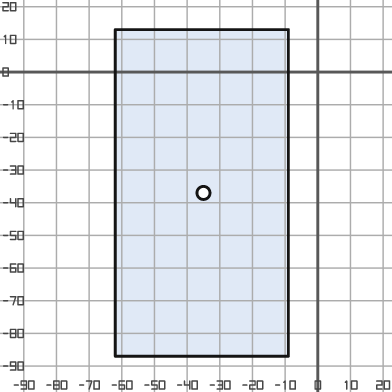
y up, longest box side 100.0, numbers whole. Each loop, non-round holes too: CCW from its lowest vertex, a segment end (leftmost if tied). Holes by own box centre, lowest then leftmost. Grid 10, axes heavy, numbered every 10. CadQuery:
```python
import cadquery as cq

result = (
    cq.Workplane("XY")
    .moveTo(-62.0, -87.0)
    .lineTo(-9.0, -87.0)
    .lineTo(-9.0, 13.0)
    .lineTo(-62.0, 13.0)
    .close()
    .moveTo(-35.0, -37.0)
    .circle(2.0)
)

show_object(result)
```